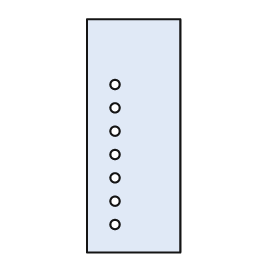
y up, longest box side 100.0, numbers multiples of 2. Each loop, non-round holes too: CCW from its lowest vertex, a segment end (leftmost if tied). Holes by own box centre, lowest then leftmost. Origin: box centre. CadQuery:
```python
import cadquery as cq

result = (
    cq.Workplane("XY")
    .moveTo(-20.0, -50.0)
    .lineTo(20.0, -50.0)
    .lineTo(20.0, 50.0)
    .lineTo(-20.0, 50.0)
    .close()
    .moveTo(-8.0, -38.0)
    .circle(2.0)
    .moveTo(-8.0, -28.0)
    .circle(2.0)
    .moveTo(-8.0, -18.0)
    .circle(2.0)
    .moveTo(-8.0, -8.0)
    .circle(2.0)
    .moveTo(-8.0, 2.0)
    .circle(2.0)
    .moveTo(-8.0, 12.0)
    .circle(2.0)
    .moveTo(-8.0, 22.0)
    .circle(2.0)
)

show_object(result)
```